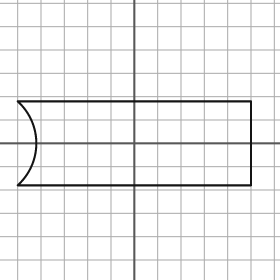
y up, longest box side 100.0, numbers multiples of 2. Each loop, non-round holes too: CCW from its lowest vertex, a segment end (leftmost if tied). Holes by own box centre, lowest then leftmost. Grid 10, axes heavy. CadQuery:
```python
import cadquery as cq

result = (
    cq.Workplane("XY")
    .moveTo(-50.0, -18.0)
    .lineTo(50.0, -18.0)
    .lineTo(50.0, 18.0)
    .lineTo(-50.0, 18.0)
    .threePointArc((-42.0, 0.0), (-50.0, -18.0))
    .close()
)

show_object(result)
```